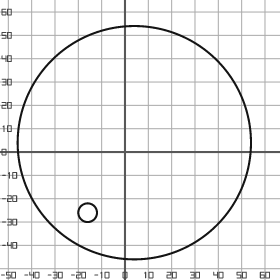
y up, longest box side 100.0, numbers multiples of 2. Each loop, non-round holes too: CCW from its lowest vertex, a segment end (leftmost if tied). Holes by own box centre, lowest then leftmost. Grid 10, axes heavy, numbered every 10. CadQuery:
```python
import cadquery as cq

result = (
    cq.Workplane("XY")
    .moveTo(4.0, 4.0)
    .circle(50.0)
    .moveTo(-16.0, -26.0)
    .circle(4.0)
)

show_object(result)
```